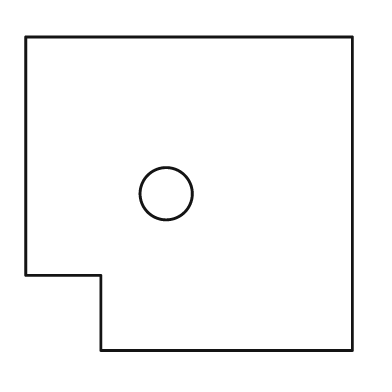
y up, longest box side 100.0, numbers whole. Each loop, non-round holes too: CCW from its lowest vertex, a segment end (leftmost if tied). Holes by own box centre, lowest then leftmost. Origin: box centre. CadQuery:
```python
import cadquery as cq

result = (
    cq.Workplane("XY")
    .moveTo(-27.0, -48.0)
    .lineTo(50.0, -48.0)
    .lineTo(50.0, 48.0)
    .lineTo(-50.0, 48.0)
    .lineTo(-50.0, -25.0)
    .lineTo(-27.0, -25.0)
    .close()
    .moveTo(-7.0, 0.0)
    .circle(8.0)
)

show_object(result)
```